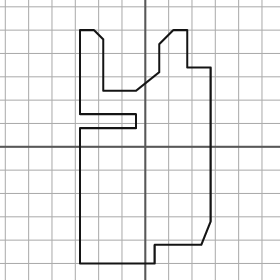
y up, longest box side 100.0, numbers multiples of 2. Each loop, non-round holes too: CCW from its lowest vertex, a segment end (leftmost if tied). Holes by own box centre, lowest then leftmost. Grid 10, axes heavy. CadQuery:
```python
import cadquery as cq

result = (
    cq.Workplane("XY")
    .moveTo(-28.0, -50.0)
    .lineTo(4.0, -50.0)
    .lineTo(4.0, -42.0)
    .lineTo(24.0, -42.0)
    .lineTo(28.0, -32.0)
    .lineTo(28.0, 34.0)
    .lineTo(18.0, 34.0)
    .lineTo(18.0, 50.0)
    .lineTo(12.0, 50.0)
    .lineTo(6.0, 44.0)
    .lineTo(6.0, 32.0)
    .lineTo(-4.0, 24.0)
    .lineTo(-18.0, 24.0)
    .lineTo(-18.0, 46.0)
    .lineTo(-22.0, 50.0)
    .lineTo(-28.0, 50.0)
    .lineTo(-28.0, 14.0)
    .lineTo(-4.0, 14.0)
    .lineTo(-4.0, 8.0)
    .lineTo(-28.0, 8.0)
    .close()
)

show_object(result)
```